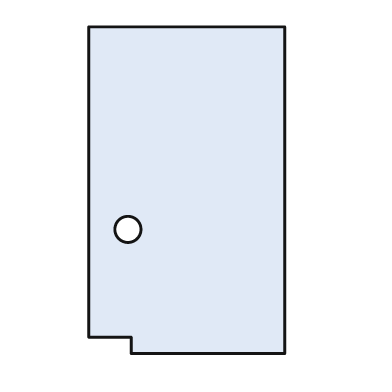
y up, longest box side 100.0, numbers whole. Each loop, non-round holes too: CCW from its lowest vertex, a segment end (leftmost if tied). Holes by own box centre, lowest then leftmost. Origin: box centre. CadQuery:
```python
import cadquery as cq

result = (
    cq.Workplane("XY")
    .moveTo(-17.0, -50.0)
    .lineTo(30.0, -50.0)
    .lineTo(30.0, 50.0)
    .lineTo(-30.0, 50.0)
    .lineTo(-30.0, -45.0)
    .lineTo(-17.0, -45.0)
    .close()
    .moveTo(-18.0, -12.0)
    .circle(4.0)
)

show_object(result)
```